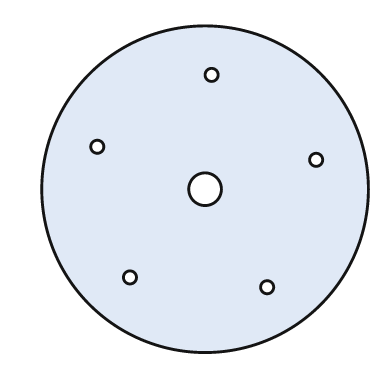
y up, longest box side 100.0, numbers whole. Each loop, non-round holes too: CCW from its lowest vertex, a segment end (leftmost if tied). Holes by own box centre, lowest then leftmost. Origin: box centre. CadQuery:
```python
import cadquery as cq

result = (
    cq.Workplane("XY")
    .moveTo(0.0, 0.0)
    .circle(50.0)
    .moveTo(19.0, -30.0)
    .circle(2.0)
    .moveTo(-23.0, -27.0)
    .circle(2.0)
    .moveTo(0.0, 0.0)
    .circle(5.0)
    .moveTo(34.0, 9.0)
    .circle(2.0)
    .moveTo(-33.0, 13.0)
    .circle(2.0)
    .moveTo(2.0, 35.0)
    .circle(2.0)
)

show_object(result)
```